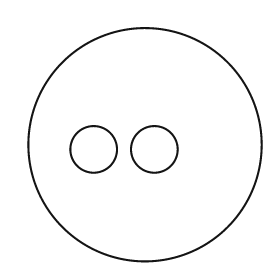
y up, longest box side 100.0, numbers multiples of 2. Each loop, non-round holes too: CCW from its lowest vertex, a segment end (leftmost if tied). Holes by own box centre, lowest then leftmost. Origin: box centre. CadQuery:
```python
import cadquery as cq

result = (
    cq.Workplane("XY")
    .moveTo(0.0, 0.0)
    .circle(50.0)
    .moveTo(-22.0, -2.0)
    .circle(10.0)
    .moveTo(4.0, -2.0)
    .circle(10.0)
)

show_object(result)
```